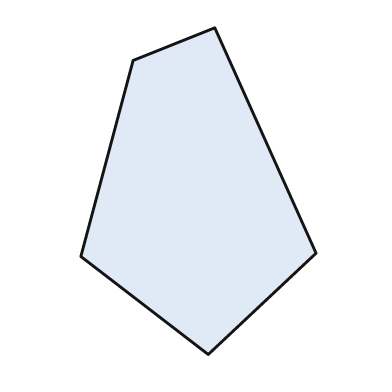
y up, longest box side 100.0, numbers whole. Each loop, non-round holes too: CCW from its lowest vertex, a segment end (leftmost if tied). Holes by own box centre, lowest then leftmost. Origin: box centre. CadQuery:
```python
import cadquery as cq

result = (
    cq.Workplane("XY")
    .moveTo(3.0, -50.0)
    .lineTo(36.0, -19.0)
    .lineTo(5.0, 50.0)
    .lineTo(-20.0, 40.0)
    .lineTo(-36.0, -20.0)
    .close()
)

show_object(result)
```